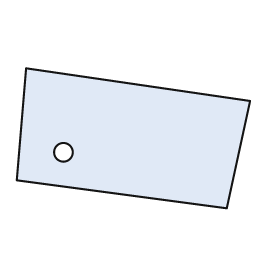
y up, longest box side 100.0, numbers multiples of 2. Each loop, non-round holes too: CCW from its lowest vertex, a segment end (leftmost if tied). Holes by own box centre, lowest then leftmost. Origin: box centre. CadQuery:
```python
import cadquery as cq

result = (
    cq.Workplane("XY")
    .moveTo(40.0, -30.0)
    .lineTo(50.0, 16.0)
    .lineTo(-46.0, 30.0)
    .lineTo(-50.0, -18.0)
    .close()
    .moveTo(-30.0, -6.0)
    .circle(4.0)
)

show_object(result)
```